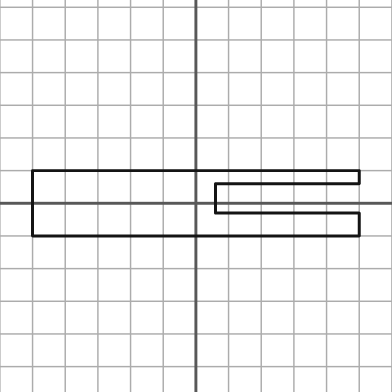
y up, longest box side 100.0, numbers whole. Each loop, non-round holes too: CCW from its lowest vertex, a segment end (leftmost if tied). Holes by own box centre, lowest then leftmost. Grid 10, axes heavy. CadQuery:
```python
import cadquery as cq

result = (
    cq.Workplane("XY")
    .moveTo(-50.0, -10.0)
    .lineTo(50.0, -10.0)
    .lineTo(50.0, -3.0)
    .lineTo(6.0, -3.0)
    .lineTo(6.0, 6.0)
    .lineTo(50.0, 6.0)
    .lineTo(50.0, 10.0)
    .lineTo(-50.0, 10.0)
    .close()
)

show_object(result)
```